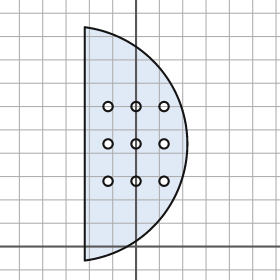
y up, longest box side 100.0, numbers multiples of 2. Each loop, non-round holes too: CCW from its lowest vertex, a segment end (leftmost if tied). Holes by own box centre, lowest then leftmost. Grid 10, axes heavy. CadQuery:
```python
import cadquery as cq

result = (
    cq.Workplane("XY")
    .moveTo(-22.0, -6.0)
    .threePointArc((22.0, 44.0), (-22.0, 94.0))
    .close()
    .moveTo(-12.0, 28.0)
    .circle(2.0)
    .moveTo(0.0, 28.0)
    .circle(2.0)
    .moveTo(12.0, 28.0)
    .circle(2.0)
    .moveTo(-12.0, 44.0)
    .circle(2.0)
    .moveTo(0.0, 44.0)
    .circle(2.0)
    .moveTo(12.0, 44.0)
    .circle(2.0)
    .moveTo(-12.0, 60.0)
    .circle(2.0)
    .moveTo(0.0, 60.0)
    .circle(2.0)
    .moveTo(12.0, 60.0)
    .circle(2.0)
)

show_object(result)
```